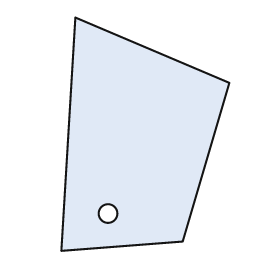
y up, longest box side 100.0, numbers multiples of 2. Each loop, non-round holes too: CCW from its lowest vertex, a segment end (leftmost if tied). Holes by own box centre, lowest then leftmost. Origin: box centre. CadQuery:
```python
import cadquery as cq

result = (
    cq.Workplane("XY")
    .moveTo(-36.0, -50.0)
    .lineTo(16.0, -46.0)
    .lineTo(36.0, 22.0)
    .lineTo(-30.0, 50.0)
    .close()
    .moveTo(-16.0, -34.0)
    .circle(4.0)
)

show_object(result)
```